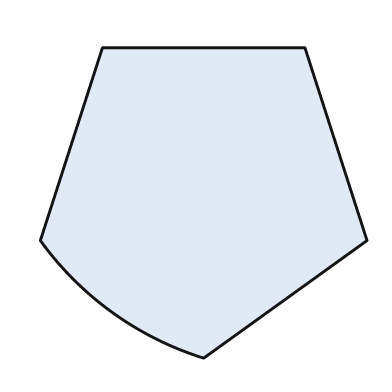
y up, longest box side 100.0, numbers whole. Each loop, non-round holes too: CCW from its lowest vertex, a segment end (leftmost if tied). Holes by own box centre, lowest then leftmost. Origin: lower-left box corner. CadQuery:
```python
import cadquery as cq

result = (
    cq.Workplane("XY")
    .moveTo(50.0, 0.0)
    .lineTo(100.0, 36.0)
    .lineTo(81.0, 95.0)
    .lineTo(19.0, 95.0)
    .lineTo(0.0, 36.0)
    .threePointArc((22.0, 14.0), (50.0, 0.0))
    .close()
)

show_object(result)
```